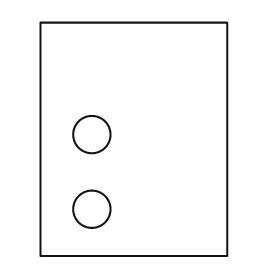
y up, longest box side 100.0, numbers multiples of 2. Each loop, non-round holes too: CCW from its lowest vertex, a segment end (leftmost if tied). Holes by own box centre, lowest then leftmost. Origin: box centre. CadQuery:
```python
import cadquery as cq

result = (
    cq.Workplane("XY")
    .moveTo(-40.0, -50.0)
    .lineTo(40.0, -50.0)
    .lineTo(40.0, 50.0)
    .lineTo(-40.0, 50.0)
    .close()
    .moveTo(-18.0, -30.0)
    .circle(8.0)
    .moveTo(-18.0, 2.0)
    .circle(8.0)
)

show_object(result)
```